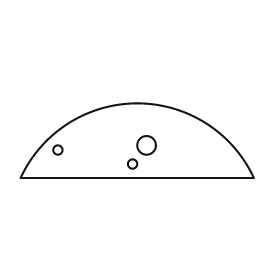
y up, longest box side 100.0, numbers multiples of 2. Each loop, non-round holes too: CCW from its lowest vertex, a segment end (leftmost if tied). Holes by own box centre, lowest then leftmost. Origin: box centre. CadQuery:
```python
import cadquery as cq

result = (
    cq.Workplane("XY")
    .moveTo(-50.0, -16.0)
    .lineTo(50.0, -16.0)
    .threePointArc((0.0, 16.0), (-50.0, -16.0))
    .close()
    .moveTo(-2.0, -10.0)
    .circle(2.0)
    .moveTo(-34.0, -4.0)
    .circle(2.0)
    .moveTo(4.0, -2.0)
    .circle(4.0)
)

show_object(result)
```